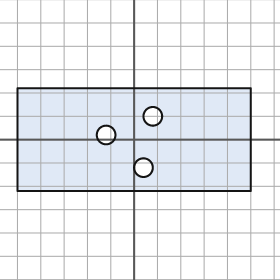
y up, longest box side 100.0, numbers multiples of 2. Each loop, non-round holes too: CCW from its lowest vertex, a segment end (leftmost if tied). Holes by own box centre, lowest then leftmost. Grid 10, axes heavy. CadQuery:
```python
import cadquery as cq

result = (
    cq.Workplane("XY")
    .moveTo(-50.0, -22.0)
    .lineTo(50.0, -22.0)
    .lineTo(50.0, 22.0)
    .lineTo(-50.0, 22.0)
    .close()
    .moveTo(4.0, -12.0)
    .circle(4.0)
    .moveTo(-12.0, 2.0)
    .circle(4.0)
    .moveTo(8.0, 10.0)
    .circle(4.0)
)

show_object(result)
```